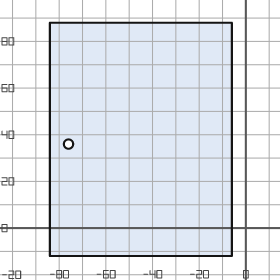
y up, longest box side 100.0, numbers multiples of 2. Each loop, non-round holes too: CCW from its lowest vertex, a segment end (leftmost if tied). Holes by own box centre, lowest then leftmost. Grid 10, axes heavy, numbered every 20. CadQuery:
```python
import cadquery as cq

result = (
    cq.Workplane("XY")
    .moveTo(-84.0, -12.0)
    .lineTo(-6.0, -12.0)
    .lineTo(-6.0, 88.0)
    .lineTo(-84.0, 88.0)
    .close()
    .moveTo(-76.0, 36.0)
    .circle(2.0)
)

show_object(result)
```